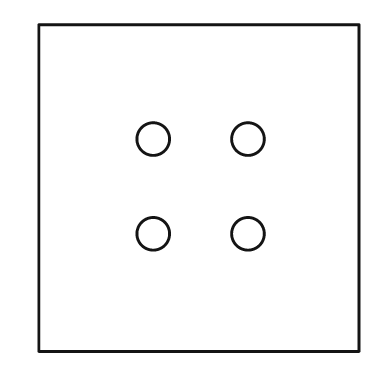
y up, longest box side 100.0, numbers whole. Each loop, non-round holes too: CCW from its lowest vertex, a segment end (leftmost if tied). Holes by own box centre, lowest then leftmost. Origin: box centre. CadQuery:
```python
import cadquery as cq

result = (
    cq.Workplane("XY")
    .moveTo(-49.0, -50.0)
    .lineTo(49.0, -50.0)
    .lineTo(49.0, 50.0)
    .lineTo(-49.0, 50.0)
    .close()
    .moveTo(-14.0, -14.0)
    .circle(5.0)
    .moveTo(15.0, -14.0)
    .circle(5.0)
    .moveTo(-14.0, 15.0)
    .circle(5.0)
    .moveTo(15.0, 15.0)
    .circle(5.0)
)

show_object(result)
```